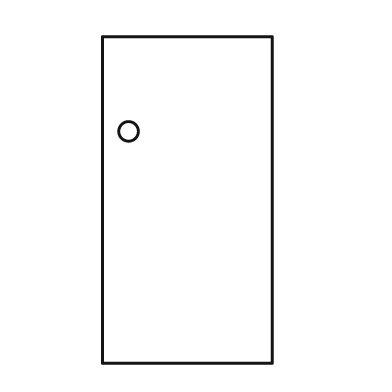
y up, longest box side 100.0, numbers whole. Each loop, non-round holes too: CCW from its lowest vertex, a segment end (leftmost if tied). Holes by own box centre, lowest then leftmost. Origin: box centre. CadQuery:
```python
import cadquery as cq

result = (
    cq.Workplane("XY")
    .moveTo(-26.0, -50.0)
    .lineTo(26.0, -50.0)
    .lineTo(26.0, 50.0)
    .lineTo(-26.0, 50.0)
    .close()
    .moveTo(-18.0, 21.0)
    .circle(3.0)
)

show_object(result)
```